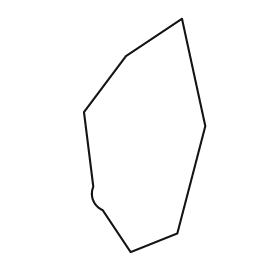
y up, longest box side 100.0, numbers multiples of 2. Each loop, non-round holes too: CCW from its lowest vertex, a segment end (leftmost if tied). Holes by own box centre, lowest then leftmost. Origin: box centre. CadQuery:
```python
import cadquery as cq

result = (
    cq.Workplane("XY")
    .moveTo(-6.0, -50.0)
    .lineTo(14.0, -42.0)
    .lineTo(26.0, 4.0)
    .lineTo(16.0, 50.0)
    .lineTo(-8.0, 34.0)
    .lineTo(-26.0, 10.0)
    .lineTo(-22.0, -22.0)
    .threePointArc((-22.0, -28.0), (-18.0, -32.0))
    .close()
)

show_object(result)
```